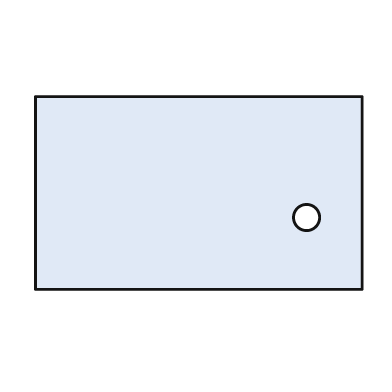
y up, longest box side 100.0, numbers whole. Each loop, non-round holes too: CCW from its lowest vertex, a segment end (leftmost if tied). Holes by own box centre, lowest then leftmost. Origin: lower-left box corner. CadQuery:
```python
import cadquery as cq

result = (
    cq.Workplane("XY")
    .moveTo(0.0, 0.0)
    .lineTo(100.0, 0.0)
    .lineTo(100.0, 59.0)
    .lineTo(0.0, 59.0)
    .close()
    .moveTo(83.0, 22.0)
    .circle(4.0)
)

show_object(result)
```